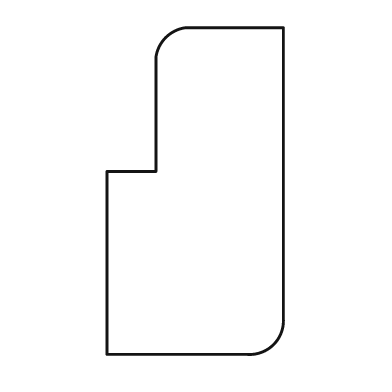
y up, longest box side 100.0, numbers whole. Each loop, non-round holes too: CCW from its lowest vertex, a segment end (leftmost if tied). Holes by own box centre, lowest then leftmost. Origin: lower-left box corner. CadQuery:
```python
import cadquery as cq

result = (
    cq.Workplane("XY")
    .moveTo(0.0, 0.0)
    .lineTo(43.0, 0.0)
    .threePointArc((51.0, 3.0), (54.0, 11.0))
    .lineTo(54.0, 100.0)
    .lineTo(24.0, 100.0)
    .threePointArc((18.0, 97.0), (15.0, 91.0))
    .lineTo(15.0, 56.0)
    .lineTo(0.0, 56.0)
    .close()
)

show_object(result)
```